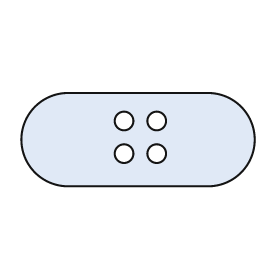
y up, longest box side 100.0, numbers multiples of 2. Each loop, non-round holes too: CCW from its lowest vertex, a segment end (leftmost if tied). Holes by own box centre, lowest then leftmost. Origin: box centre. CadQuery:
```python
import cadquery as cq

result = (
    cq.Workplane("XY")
    .moveTo(-30.0, -20.0)
    .lineTo(30.0, -20.0)
    .threePointArc((50.0, 0.0), (30.0, 20.0))
    .lineTo(-30.0, 20.0)
    .threePointArc((-50.0, 0.0), (-30.0, -20.0))
    .close()
    .moveTo(-6.0, -6.0)
    .circle(4.0)
    .moveTo(8.0, -6.0)
    .circle(4.0)
    .moveTo(-6.0, 8.0)
    .circle(4.0)
    .moveTo(8.0, 8.0)
    .circle(4.0)
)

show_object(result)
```